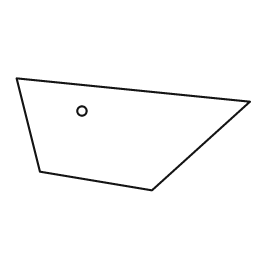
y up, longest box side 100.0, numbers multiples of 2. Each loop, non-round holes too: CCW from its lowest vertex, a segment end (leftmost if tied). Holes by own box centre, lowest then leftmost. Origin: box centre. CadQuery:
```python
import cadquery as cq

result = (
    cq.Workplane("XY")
    .moveTo(8.0, -24.0)
    .lineTo(50.0, 14.0)
    .lineTo(-50.0, 24.0)
    .lineTo(-40.0, -16.0)
    .close()
    .moveTo(-22.0, 10.0)
    .circle(2.0)
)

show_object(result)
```